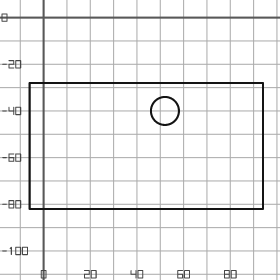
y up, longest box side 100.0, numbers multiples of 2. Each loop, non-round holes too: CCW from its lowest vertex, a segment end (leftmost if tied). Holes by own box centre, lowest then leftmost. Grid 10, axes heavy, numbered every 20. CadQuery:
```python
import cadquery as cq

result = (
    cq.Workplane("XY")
    .moveTo(-6.0, -82.0)
    .lineTo(94.0, -82.0)
    .lineTo(94.0, -28.0)
    .lineTo(-6.0, -28.0)
    .close()
    .moveTo(52.0, -40.0)
    .circle(6.0)
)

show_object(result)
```